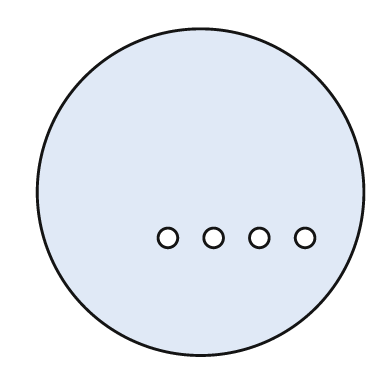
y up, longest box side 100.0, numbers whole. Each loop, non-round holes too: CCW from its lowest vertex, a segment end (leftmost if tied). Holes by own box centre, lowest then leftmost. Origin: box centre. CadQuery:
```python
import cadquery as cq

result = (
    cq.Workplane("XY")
    .moveTo(0.0, 0.0)
    .circle(50.0)
    .moveTo(-10.0, -14.0)
    .circle(3.0)
    .moveTo(4.0, -14.0)
    .circle(3.0)
    .moveTo(18.0, -14.0)
    .circle(3.0)
    .moveTo(32.0, -14.0)
    .circle(3.0)
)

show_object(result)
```